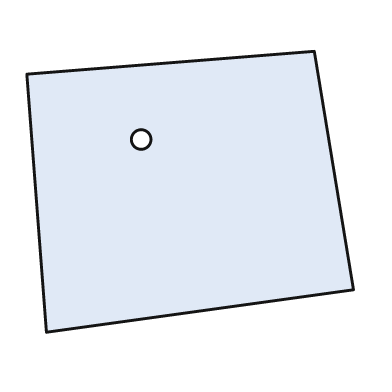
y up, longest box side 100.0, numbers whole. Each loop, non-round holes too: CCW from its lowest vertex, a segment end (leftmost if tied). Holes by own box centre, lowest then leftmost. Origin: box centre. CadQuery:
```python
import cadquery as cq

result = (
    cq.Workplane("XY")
    .moveTo(-44.0, -43.0)
    .lineTo(50.0, -30.0)
    .lineTo(38.0, 43.0)
    .lineTo(-50.0, 36.0)
    .close()
    .moveTo(-15.0, 16.0)
    .circle(3.0)
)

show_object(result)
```